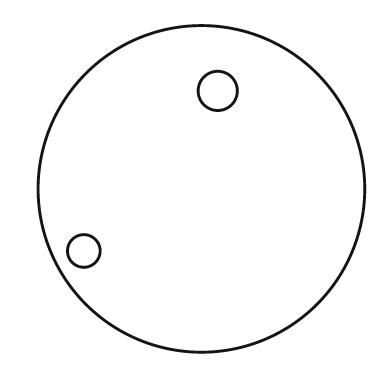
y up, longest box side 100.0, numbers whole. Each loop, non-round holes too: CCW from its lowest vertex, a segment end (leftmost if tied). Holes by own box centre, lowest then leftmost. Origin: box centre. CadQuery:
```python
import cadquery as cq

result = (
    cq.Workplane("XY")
    .moveTo(0.0, 0.0)
    .circle(50.0)
    .moveTo(-36.0, -19.0)
    .circle(5.0)
    .moveTo(5.0, 30.0)
    .circle(6.0)
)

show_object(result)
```